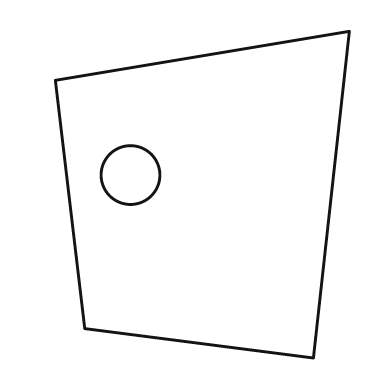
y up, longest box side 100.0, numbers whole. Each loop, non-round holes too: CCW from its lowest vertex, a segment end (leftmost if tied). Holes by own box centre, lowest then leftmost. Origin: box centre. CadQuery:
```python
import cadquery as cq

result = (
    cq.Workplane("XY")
    .moveTo(34.0, -50.0)
    .lineTo(45.0, 50.0)
    .lineTo(-45.0, 35.0)
    .lineTo(-36.0, -41.0)
    .close()
    .moveTo(-22.0, 6.0)
    .circle(9.0)
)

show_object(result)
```